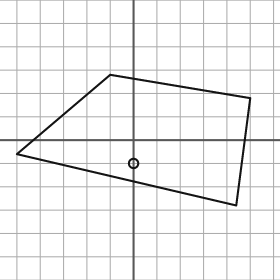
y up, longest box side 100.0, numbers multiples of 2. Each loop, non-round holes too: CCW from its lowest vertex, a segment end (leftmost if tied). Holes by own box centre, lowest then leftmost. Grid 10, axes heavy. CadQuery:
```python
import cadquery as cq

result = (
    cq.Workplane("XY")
    .moveTo(44.0, -28.0)
    .lineTo(50.0, 18.0)
    .lineTo(-10.0, 28.0)
    .lineTo(-50.0, -6.0)
    .close()
    .moveTo(0.0, -10.0)
    .circle(2.0)
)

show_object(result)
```